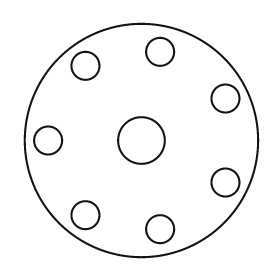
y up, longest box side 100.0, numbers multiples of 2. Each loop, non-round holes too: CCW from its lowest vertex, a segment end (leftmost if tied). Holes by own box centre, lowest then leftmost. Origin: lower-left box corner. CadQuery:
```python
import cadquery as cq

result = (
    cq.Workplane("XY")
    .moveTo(50.0, 50.0)
    .circle(50.0)
    .moveTo(58.0, 12.0)
    .circle(6.0)
    .moveTo(26.0, 18.0)
    .circle(6.0)
    .moveTo(86.0, 32.0)
    .circle(6.0)
    .moveTo(10.0, 50.0)
    .circle(6.0)
    .moveTo(50.0, 50.0)
    .circle(10.0)
    .moveTo(86.0, 68.0)
    .circle(6.0)
    .moveTo(26.0, 82.0)
    .circle(6.0)
    .moveTo(58.0, 88.0)
    .circle(6.0)
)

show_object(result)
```